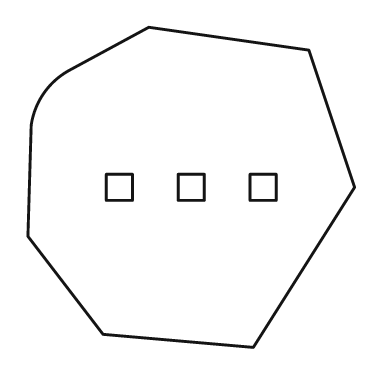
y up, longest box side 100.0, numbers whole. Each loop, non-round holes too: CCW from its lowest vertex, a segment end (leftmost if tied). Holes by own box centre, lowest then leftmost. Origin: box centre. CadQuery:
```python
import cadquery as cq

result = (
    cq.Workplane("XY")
    .moveTo(19.0, -49.0)
    .lineTo(50.0, 0.0)
    .lineTo(36.0, 42.0)
    .lineTo(-13.0, 49.0)
    .lineTo(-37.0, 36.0)
    .threePointArc((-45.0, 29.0), (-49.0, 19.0))
    .lineTo(-50.0, -15.0)
    .lineTo(-27.0, -45.0)
    .close()
    .moveTo(-26.0, -4.0)
    .lineTo(-18.0, -4.0)
    .lineTo(-18.0, 4.0)
    .lineTo(-26.0, 4.0)
    .close()
    .moveTo(-4.0, -4.0)
    .lineTo(4.0, -4.0)
    .lineTo(4.0, 4.0)
    .lineTo(-4.0, 4.0)
    .close()
    .moveTo(18.0, -4.0)
    .lineTo(26.0, -4.0)
    .lineTo(26.0, 4.0)
    .lineTo(18.0, 4.0)
    .close()
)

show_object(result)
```